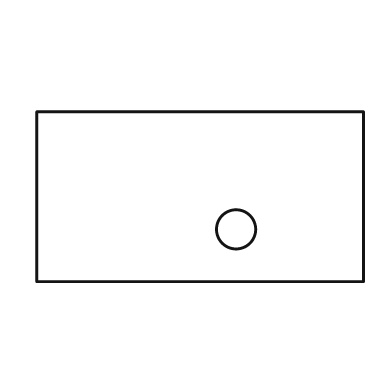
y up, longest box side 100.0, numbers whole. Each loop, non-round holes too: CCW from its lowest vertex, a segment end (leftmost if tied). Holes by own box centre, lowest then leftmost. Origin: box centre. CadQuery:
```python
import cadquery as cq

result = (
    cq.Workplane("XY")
    .moveTo(-50.0, -26.0)
    .lineTo(50.0, -26.0)
    .lineTo(50.0, 26.0)
    .lineTo(-50.0, 26.0)
    .close()
    .moveTo(11.0, -10.0)
    .circle(6.0)
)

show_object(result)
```